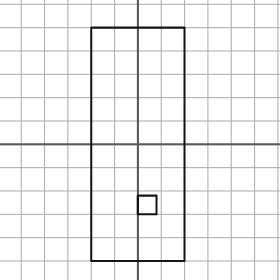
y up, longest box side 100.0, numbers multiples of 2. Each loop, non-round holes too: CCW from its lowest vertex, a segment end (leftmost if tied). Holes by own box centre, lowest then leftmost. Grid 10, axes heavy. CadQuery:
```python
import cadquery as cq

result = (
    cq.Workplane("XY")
    .moveTo(-20.0, -50.0)
    .lineTo(20.0, -50.0)
    .lineTo(20.0, 50.0)
    .lineTo(-20.0, 50.0)
    .close()
    .moveTo(0.0, -30.0)
    .lineTo(8.0, -30.0)
    .lineTo(8.0, -22.0)
    .lineTo(0.0, -22.0)
    .close()
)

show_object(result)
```